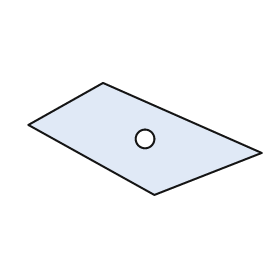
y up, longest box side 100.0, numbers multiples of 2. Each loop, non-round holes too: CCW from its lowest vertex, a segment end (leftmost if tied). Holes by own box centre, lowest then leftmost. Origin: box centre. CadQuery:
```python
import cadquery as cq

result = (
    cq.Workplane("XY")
    .moveTo(4.0, -24.0)
    .lineTo(50.0, -6.0)
    .lineTo(-18.0, 24.0)
    .lineTo(-50.0, 6.0)
    .close()
    .moveTo(0.0, 0.0)
    .circle(4.0)
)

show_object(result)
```